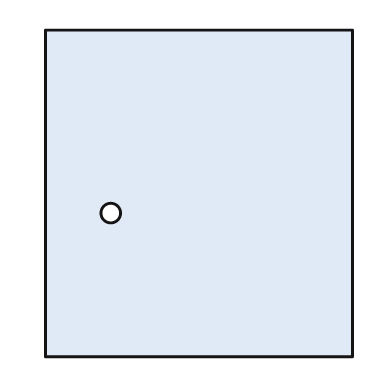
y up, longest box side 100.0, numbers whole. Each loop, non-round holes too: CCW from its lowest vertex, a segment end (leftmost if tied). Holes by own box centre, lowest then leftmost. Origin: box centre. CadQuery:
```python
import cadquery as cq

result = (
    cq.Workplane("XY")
    .moveTo(-47.0, -50.0)
    .lineTo(47.0, -50.0)
    .lineTo(47.0, 50.0)
    .lineTo(-47.0, 50.0)
    .close()
    .moveTo(-27.0, -6.0)
    .circle(3.0)
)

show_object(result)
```